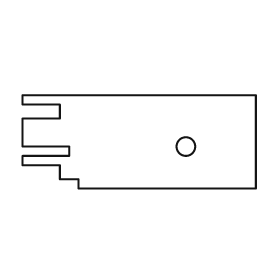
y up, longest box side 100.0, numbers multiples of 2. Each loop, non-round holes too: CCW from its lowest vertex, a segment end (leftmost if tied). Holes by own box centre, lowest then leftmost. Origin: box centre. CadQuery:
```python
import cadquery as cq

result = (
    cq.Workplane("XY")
    .moveTo(-26.0, -20.0)
    .lineTo(50.0, -20.0)
    .lineTo(50.0, 20.0)
    .lineTo(-50.0, 20.0)
    .lineTo(-50.0, 16.0)
    .lineTo(-34.0, 16.0)
    .lineTo(-34.0, 10.0)
    .lineTo(-50.0, 10.0)
    .lineTo(-50.0, -2.0)
    .lineTo(-30.0, -2.0)
    .lineTo(-30.0, -6.0)
    .lineTo(-50.0, -6.0)
    .lineTo(-50.0, -10.0)
    .lineTo(-34.0, -10.0)
    .lineTo(-34.0, -16.0)
    .lineTo(-26.0, -16.0)
    .close()
    .moveTo(20.0, -2.0)
    .circle(4.0)
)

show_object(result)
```